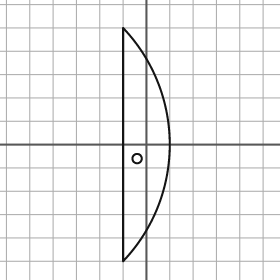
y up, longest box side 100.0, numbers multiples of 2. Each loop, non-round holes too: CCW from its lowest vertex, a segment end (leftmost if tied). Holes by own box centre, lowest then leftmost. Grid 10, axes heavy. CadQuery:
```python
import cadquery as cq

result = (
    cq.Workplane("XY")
    .moveTo(-10.0, -50.0)
    .threePointArc((10.0, 0.0), (-10.0, 50.0))
    .close()
    .moveTo(-4.0, -6.0)
    .circle(2.0)
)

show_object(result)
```